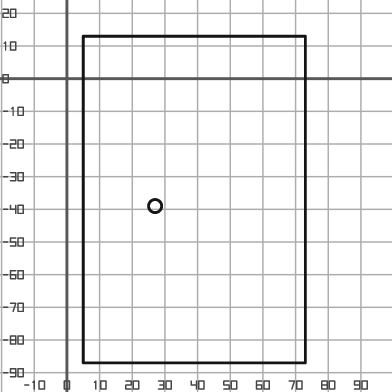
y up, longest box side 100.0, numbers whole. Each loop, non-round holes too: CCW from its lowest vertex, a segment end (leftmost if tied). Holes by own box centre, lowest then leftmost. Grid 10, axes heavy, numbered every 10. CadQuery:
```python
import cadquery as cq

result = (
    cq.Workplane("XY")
    .moveTo(5.0, -87.0)
    .lineTo(73.0, -87.0)
    .lineTo(73.0, 13.0)
    .lineTo(5.0, 13.0)
    .close()
    .moveTo(27.0, -39.0)
    .circle(2.0)
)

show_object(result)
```